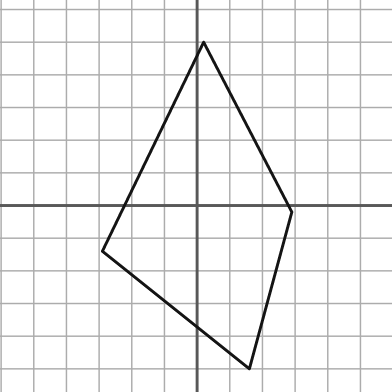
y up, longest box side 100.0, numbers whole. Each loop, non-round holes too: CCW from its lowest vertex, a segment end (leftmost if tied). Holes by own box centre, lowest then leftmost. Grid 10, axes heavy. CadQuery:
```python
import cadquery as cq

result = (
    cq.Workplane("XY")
    .moveTo(16.0, -50.0)
    .lineTo(29.0, -2.0)
    .lineTo(2.0, 50.0)
    .lineTo(-29.0, -14.0)
    .close()
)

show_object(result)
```